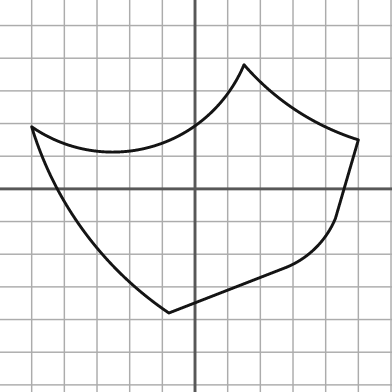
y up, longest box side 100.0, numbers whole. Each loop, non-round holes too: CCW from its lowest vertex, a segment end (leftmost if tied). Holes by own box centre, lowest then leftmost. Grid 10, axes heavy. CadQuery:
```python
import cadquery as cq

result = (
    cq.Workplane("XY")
    .moveTo(-8.0, -38.0)
    .lineTo(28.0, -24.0)
    .threePointArc((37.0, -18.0), (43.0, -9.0))
    .lineTo(50.0, 15.0)
    .threePointArc((31.0, 24.0), (15.0, 38.0))
    .threePointArc((-13.0, 13.0), (-50.0, 19.0))
    .threePointArc((-34.0, -13.0), (-8.0, -38.0))
    .close()
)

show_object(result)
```